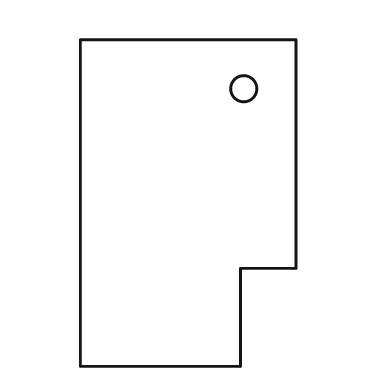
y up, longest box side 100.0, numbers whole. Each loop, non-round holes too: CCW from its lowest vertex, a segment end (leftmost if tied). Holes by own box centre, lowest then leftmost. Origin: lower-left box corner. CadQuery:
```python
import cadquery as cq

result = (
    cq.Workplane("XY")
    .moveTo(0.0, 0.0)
    .lineTo(49.0, 0.0)
    .lineTo(49.0, 30.0)
    .lineTo(66.0, 30.0)
    .lineTo(66.0, 100.0)
    .lineTo(0.0, 100.0)
    .close()
    .moveTo(50.0, 85.0)
    .circle(4.0)
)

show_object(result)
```